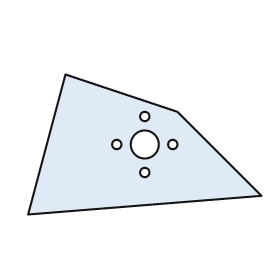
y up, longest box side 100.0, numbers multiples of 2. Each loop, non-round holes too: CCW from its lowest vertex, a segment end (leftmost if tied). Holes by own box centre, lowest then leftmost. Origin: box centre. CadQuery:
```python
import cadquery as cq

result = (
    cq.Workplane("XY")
    .moveTo(-50.0, -30.0)
    .lineTo(50.0, -22.0)
    .lineTo(14.0, 14.0)
    .lineTo(-34.0, 30.0)
    .close()
    .moveTo(0.0, -12.0)
    .circle(2.0)
    .moveTo(-12.0, 0.0)
    .circle(2.0)
    .moveTo(0.0, 0.0)
    .circle(6.0)
    .moveTo(12.0, 0.0)
    .circle(2.0)
    .moveTo(0.0, 12.0)
    .circle(2.0)
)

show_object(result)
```